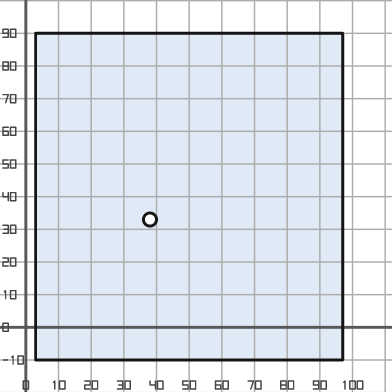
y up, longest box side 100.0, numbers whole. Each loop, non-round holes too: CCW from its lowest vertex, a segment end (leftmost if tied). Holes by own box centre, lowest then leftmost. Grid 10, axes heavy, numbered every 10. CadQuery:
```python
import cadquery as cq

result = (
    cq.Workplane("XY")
    .moveTo(3.0, -10.0)
    .lineTo(97.0, -10.0)
    .lineTo(97.0, 90.0)
    .lineTo(3.0, 90.0)
    .close()
    .moveTo(38.0, 33.0)
    .circle(2.0)
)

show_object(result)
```